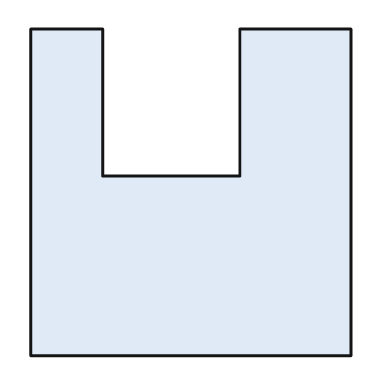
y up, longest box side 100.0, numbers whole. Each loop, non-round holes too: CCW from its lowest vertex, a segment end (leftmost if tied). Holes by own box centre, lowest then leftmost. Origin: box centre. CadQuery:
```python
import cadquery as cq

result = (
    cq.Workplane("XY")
    .moveTo(-49.0, -50.0)
    .lineTo(49.0, -50.0)
    .lineTo(49.0, 50.0)
    .lineTo(15.0, 50.0)
    .lineTo(15.0, 5.0)
    .lineTo(-27.0, 5.0)
    .lineTo(-27.0, 50.0)
    .lineTo(-49.0, 50.0)
    .close()
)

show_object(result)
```